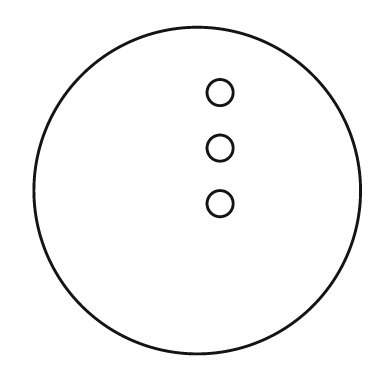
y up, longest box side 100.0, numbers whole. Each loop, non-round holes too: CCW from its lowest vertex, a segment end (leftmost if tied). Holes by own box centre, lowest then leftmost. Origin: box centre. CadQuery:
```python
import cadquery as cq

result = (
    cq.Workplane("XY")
    .moveTo(0.0, 0.0)
    .circle(50.0)
    .moveTo(7.0, -4.0)
    .circle(4.0)
    .moveTo(7.0, 13.0)
    .circle(4.0)
    .moveTo(7.0, 30.0)
    .circle(4.0)
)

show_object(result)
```